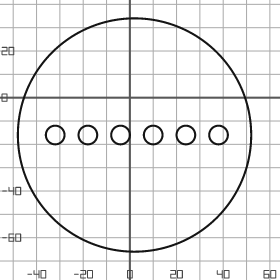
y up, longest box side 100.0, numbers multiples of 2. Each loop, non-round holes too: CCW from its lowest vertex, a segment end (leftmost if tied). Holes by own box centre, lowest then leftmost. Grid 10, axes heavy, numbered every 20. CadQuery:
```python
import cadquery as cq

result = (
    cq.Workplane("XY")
    .moveTo(2.0, -16.0)
    .circle(50.0)
    .moveTo(-32.0, -16.0)
    .circle(4.0)
    .moveTo(-18.0, -16.0)
    .circle(4.0)
    .moveTo(-4.0, -16.0)
    .circle(4.0)
    .moveTo(10.0, -16.0)
    .circle(4.0)
    .moveTo(24.0, -16.0)
    .circle(4.0)
    .moveTo(38.0, -16.0)
    .circle(4.0)
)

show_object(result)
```